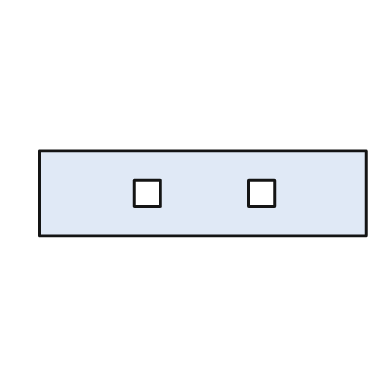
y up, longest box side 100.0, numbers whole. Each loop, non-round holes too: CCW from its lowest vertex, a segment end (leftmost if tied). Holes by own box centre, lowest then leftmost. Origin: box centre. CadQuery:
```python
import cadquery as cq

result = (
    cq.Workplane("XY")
    .moveTo(-50.0, -13.0)
    .lineTo(50.0, -13.0)
    .lineTo(50.0, 13.0)
    .lineTo(-50.0, 13.0)
    .close()
    .moveTo(-21.0, -4.0)
    .lineTo(-13.0, -4.0)
    .lineTo(-13.0, 4.0)
    .lineTo(-21.0, 4.0)
    .close()
    .moveTo(14.0, -4.0)
    .lineTo(22.0, -4.0)
    .lineTo(22.0, 4.0)
    .lineTo(14.0, 4.0)
    .close()
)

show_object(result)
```